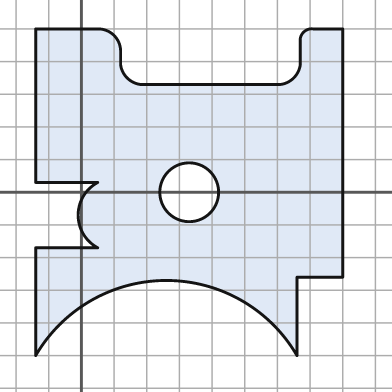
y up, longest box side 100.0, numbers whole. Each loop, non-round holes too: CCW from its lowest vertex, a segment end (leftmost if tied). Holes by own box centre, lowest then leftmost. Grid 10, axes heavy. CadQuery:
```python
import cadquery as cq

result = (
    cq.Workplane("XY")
    .moveTo(-14.0, -50.0)
    .threePointArc((26.0, -27.0), (66.0, -50.0))
    .lineTo(66.0, -26.0)
    .lineTo(80.0, -26.0)
    .lineTo(80.0, 50.0)
    .lineTo(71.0, 50.0)
    .threePointArc((68.0, 49.0), (67.0, 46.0))
    .lineTo(67.0, 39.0)
    .threePointArc((65.0, 35.0), (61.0, 33.0))
    .lineTo(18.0, 33.0)
    .threePointArc((14.0, 35.0), (12.0, 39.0))
    .lineTo(12.0, 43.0)
    .threePointArc((10.0, 48.0), (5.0, 50.0))
    .lineTo(-14.0, 50.0)
    .lineTo(-14.0, 3.0)
    .lineTo(5.0, 3.0)
    .threePointArc((-1.0, -7.0), (5.0, -17.0))
    .lineTo(-14.0, -17.0)
    .close()
    .moveTo(33.0, 0.0)
    .circle(9.0)
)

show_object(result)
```